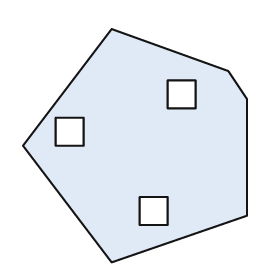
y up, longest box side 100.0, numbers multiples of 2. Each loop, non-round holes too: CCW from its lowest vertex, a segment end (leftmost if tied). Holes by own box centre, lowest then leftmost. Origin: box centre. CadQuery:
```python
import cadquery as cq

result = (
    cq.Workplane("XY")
    .moveTo(-10.0, -50.0)
    .lineTo(48.0, -30.0)
    .lineTo(48.0, 20.0)
    .lineTo(40.0, 32.0)
    .lineTo(-10.0, 50.0)
    .lineTo(-48.0, 0.0)
    .close()
    .moveTo(2.0, -34.0)
    .lineTo(14.0, -34.0)
    .lineTo(14.0, -22.0)
    .lineTo(2.0, -22.0)
    .close()
    .moveTo(-34.0, 0.0)
    .lineTo(-22.0, 0.0)
    .lineTo(-22.0, 12.0)
    .lineTo(-34.0, 12.0)
    .close()
    .moveTo(14.0, 16.0)
    .lineTo(26.0, 16.0)
    .lineTo(26.0, 28.0)
    .lineTo(14.0, 28.0)
    .close()
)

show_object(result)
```